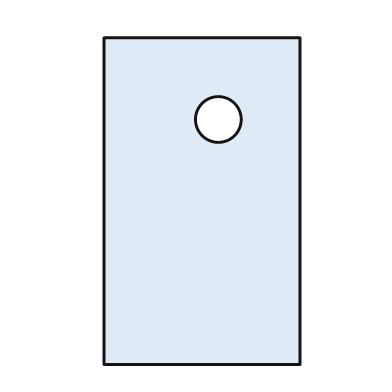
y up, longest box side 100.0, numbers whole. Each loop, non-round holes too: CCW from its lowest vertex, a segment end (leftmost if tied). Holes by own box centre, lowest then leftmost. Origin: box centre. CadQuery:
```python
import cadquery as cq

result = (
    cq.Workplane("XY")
    .moveTo(-30.0, -50.0)
    .lineTo(30.0, -50.0)
    .lineTo(30.0, 50.0)
    .lineTo(-30.0, 50.0)
    .close()
    .moveTo(5.0, 25.0)
    .circle(7.0)
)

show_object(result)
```